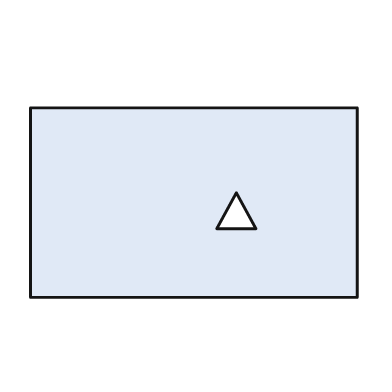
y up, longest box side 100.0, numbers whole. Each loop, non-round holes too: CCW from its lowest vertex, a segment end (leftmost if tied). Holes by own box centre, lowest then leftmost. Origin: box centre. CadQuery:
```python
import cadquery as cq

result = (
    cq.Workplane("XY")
    .moveTo(-50.0, -29.0)
    .lineTo(50.0, -29.0)
    .lineTo(50.0, 29.0)
    .lineTo(-50.0, 29.0)
    .close()
    .moveTo(7.0, -8.0)
    .lineTo(19.0, -8.0)
    .lineTo(13.0, 3.0)
    .close()
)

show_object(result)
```